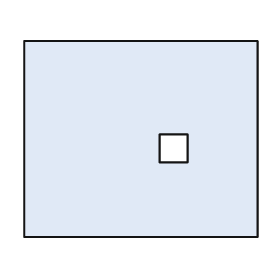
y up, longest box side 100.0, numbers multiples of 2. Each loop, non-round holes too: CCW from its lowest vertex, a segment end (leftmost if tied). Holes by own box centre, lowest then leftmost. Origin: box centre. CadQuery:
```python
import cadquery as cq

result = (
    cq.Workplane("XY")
    .moveTo(-50.0, -42.0)
    .lineTo(50.0, -42.0)
    .lineTo(50.0, 42.0)
    .lineTo(-50.0, 42.0)
    .close()
    .moveTo(8.0, -10.0)
    .lineTo(20.0, -10.0)
    .lineTo(20.0, 2.0)
    .lineTo(8.0, 2.0)
    .close()
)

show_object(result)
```